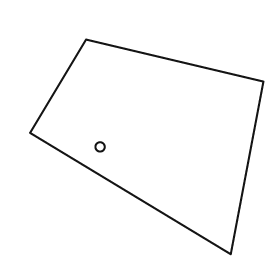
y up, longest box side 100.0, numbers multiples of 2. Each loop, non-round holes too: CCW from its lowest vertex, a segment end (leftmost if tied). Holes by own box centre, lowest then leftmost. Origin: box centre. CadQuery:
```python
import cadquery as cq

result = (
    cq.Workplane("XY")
    .moveTo(36.0, -46.0)
    .lineTo(50.0, 28.0)
    .lineTo(-26.0, 46.0)
    .lineTo(-50.0, 6.0)
    .close()
    .moveTo(-20.0, 0.0)
    .circle(2.0)
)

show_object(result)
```